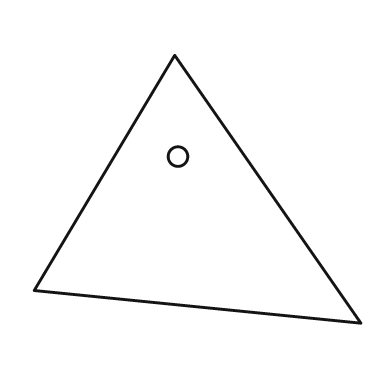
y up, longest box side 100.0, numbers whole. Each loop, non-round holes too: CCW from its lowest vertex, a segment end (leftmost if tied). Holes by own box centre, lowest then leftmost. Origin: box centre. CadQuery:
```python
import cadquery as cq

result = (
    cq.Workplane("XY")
    .moveTo(50.0, -41.0)
    .lineTo(-7.0, 41.0)
    .lineTo(-50.0, -31.0)
    .close()
    .moveTo(-6.0, 10.0)
    .circle(3.0)
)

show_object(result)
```